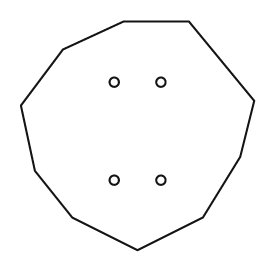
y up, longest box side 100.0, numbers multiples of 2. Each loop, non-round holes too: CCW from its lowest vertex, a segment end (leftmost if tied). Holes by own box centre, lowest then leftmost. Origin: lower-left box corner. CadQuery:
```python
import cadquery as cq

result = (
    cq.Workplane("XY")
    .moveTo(50.0, 0.0)
    .lineTo(78.0, 14.0)
    .lineTo(94.0, 40.0)
    .lineTo(100.0, 64.0)
    .lineTo(72.0, 98.0)
    .lineTo(44.0, 98.0)
    .lineTo(18.0, 86.0)
    .lineTo(0.0, 62.0)
    .lineTo(6.0, 34.0)
    .lineTo(22.0, 14.0)
    .close()
    .moveTo(40.0, 30.0)
    .circle(2.0)
    .moveTo(60.0, 30.0)
    .circle(2.0)
    .moveTo(40.0, 72.0)
    .circle(2.0)
    .moveTo(60.0, 72.0)
    .circle(2.0)
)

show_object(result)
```